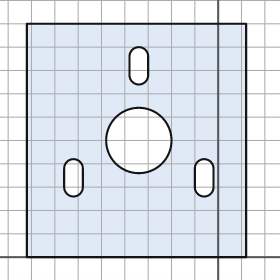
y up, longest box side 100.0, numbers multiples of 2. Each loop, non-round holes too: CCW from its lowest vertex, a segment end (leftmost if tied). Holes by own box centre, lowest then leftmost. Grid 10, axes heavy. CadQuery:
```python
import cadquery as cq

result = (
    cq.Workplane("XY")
    .moveTo(-82.0, 0.0)
    .lineTo(12.0, 0.0)
    .lineTo(12.0, 100.0)
    .lineTo(-82.0, 100.0)
    .close()
    .moveTo(-66.0, 30.0)
    .threePointArc((-62.0, 26.0), (-58.0, 30.0))
    .lineTo(-58.0, 38.0)
    .threePointArc((-62.0, 42.0), (-66.0, 38.0))
    .close()
    .moveTo(-10.0, 30.0)
    .threePointArc((-6.0, 26.0), (-2.0, 30.0))
    .lineTo(-2.0, 38.0)
    .threePointArc((-6.0, 42.0), (-10.0, 38.0))
    .close()
    .moveTo(-34.0, 50.0)
    .circle(14.0)
    .moveTo(-38.0, 78.0)
    .threePointArc((-34.0, 74.0), (-30.0, 78.0))
    .lineTo(-30.0, 86.0)
    .threePointArc((-34.0, 90.0), (-38.0, 86.0))
    .close()
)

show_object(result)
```